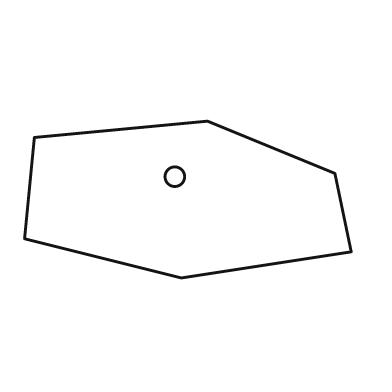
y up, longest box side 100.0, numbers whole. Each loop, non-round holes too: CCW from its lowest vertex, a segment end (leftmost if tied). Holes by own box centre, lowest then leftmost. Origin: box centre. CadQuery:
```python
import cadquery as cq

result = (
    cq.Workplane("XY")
    .moveTo(-2.0, -24.0)
    .lineTo(50.0, -16.0)
    .lineTo(45.0, 8.0)
    .lineTo(6.0, 24.0)
    .lineTo(-47.0, 19.0)
    .lineTo(-50.0, -12.0)
    .close()
    .moveTo(-4.0, 7.0)
    .circle(3.0)
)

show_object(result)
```